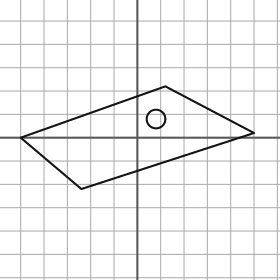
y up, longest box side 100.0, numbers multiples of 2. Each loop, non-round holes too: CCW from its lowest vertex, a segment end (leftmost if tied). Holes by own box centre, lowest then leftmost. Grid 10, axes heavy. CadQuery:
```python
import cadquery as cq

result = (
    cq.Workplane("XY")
    .moveTo(-24.0, -22.0)
    .lineTo(50.0, 2.0)
    .lineTo(12.0, 22.0)
    .lineTo(-50.0, 0.0)
    .close()
    .moveTo(8.0, 8.0)
    .circle(4.0)
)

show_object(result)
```